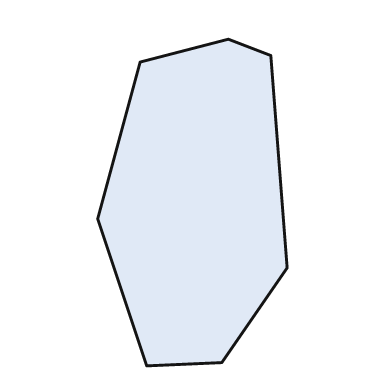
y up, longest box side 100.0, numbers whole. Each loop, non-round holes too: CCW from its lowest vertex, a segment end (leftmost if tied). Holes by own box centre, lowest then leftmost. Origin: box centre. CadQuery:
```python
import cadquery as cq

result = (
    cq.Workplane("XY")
    .moveTo(-14.0, -50.0)
    .lineTo(9.0, -49.0)
    .lineTo(29.0, -20.0)
    .lineTo(24.0, 45.0)
    .lineTo(11.0, 50.0)
    .lineTo(-16.0, 43.0)
    .lineTo(-29.0, -5.0)
    .close()
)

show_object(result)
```